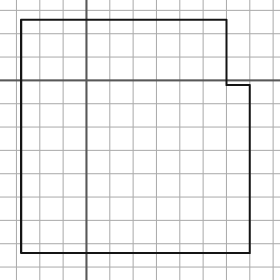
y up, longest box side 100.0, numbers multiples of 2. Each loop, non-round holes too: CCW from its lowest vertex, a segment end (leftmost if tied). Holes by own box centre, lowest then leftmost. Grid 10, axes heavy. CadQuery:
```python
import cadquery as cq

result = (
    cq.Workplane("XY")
    .moveTo(-28.0, -74.0)
    .lineTo(70.0, -74.0)
    .lineTo(70.0, -2.0)
    .lineTo(60.0, -2.0)
    .lineTo(60.0, 26.0)
    .lineTo(-28.0, 26.0)
    .close()
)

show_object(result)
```